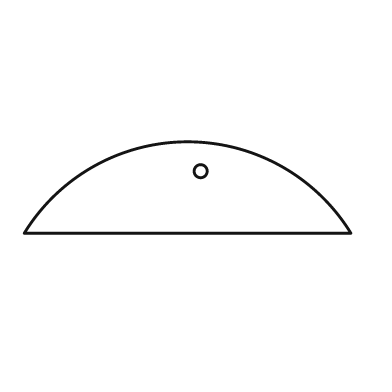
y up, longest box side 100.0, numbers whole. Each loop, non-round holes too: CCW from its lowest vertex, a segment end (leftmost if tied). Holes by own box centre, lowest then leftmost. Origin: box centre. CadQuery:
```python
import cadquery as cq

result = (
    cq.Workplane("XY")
    .moveTo(-50.0, -14.0)
    .lineTo(50.0, -14.0)
    .threePointArc((0.0, 14.0), (-50.0, -14.0))
    .close()
    .moveTo(4.0, 5.0)
    .circle(2.0)
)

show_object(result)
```